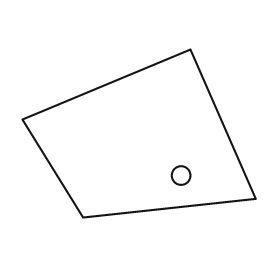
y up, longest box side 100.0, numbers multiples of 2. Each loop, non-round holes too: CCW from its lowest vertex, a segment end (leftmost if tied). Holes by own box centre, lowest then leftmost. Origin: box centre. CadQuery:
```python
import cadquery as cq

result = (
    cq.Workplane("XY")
    .moveTo(-24.0, -36.0)
    .lineTo(50.0, -28.0)
    .lineTo(22.0, 36.0)
    .lineTo(-50.0, 6.0)
    .close()
    .moveTo(18.0, -18.0)
    .circle(4.0)
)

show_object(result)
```